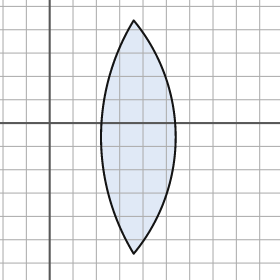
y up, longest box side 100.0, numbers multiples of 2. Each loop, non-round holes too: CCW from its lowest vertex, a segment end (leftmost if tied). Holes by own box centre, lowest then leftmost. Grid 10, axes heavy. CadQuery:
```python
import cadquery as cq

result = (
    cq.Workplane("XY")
    .moveTo(36.0, -56.0)
    .threePointArc((54.0, -6.0), (36.0, 44.0))
    .threePointArc((22.0, -6.0), (36.0, -56.0))
    .close()
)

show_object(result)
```